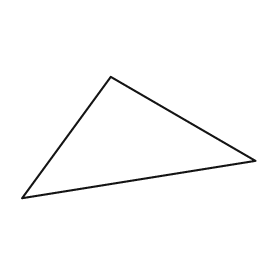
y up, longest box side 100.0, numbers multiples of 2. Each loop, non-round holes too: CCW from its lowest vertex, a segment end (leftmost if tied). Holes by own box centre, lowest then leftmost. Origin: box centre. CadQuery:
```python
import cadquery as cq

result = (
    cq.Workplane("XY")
    .moveTo(-50.0, -26.0)
    .lineTo(50.0, -10.0)
    .lineTo(-12.0, 26.0)
    .close()
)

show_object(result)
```